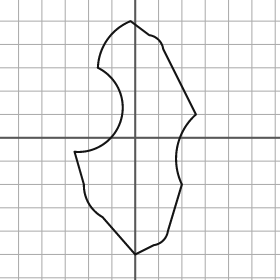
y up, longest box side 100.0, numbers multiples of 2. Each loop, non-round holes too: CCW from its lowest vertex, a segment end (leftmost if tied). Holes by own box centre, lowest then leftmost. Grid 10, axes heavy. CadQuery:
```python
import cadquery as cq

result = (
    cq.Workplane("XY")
    .moveTo(0.0, -50.0)
    .lineTo(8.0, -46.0)
    .threePointArc((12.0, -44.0), (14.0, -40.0))
    .lineTo(20.0, -20.0)
    .threePointArc((18.0, -4.0), (26.0, 10.0))
    .lineTo(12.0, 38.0)
    .threePointArc((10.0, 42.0), (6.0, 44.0))
    .lineTo(-2.0, 50.0)
    .threePointArc((-12.0, 42.0), (-16.0, 30.0))
    .threePointArc((-6.0, 8.0), (-26.0, -6.0))
    .lineTo(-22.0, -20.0)
    .threePointArc((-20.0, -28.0), (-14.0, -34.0))
    .close()
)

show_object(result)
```